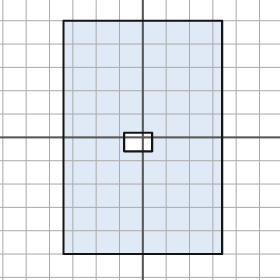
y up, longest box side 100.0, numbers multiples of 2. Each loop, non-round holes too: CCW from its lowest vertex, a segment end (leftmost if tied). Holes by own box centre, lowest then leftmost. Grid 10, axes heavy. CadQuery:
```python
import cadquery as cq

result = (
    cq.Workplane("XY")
    .moveTo(-34.0, -50.0)
    .lineTo(34.0, -50.0)
    .lineTo(34.0, 50.0)
    .lineTo(-34.0, 50.0)
    .close()
    .moveTo(-8.0, -6.0)
    .lineTo(4.0, -6.0)
    .lineTo(4.0, 2.0)
    .lineTo(-8.0, 2.0)
    .close()
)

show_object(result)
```